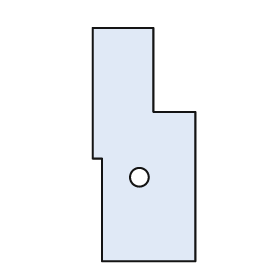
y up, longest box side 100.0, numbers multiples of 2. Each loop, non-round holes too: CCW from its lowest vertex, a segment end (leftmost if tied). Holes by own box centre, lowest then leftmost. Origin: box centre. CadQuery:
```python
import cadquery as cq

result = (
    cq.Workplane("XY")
    .moveTo(-18.0, -50.0)
    .lineTo(22.0, -50.0)
    .lineTo(22.0, 14.0)
    .lineTo(4.0, 14.0)
    .lineTo(4.0, 50.0)
    .lineTo(-22.0, 50.0)
    .lineTo(-22.0, -6.0)
    .lineTo(-18.0, -6.0)
    .close()
    .moveTo(-2.0, -14.0)
    .circle(4.0)
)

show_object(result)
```